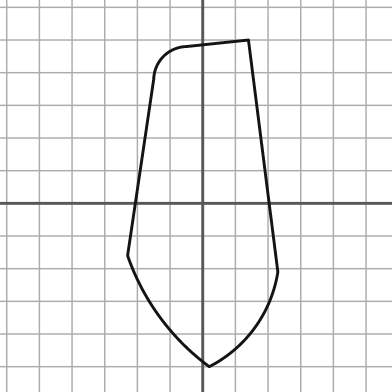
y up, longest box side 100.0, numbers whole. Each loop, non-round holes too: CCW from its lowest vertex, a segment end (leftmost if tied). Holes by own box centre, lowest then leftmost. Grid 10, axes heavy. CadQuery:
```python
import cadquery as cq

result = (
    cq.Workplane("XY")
    .moveTo(2.0, -50.0)
    .threePointArc((16.0, -38.0), (23.0, -21.0))
    .lineTo(14.0, 50.0)
    .lineTo(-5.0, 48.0)
    .threePointArc((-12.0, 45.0), (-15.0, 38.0))
    .lineTo(-23.0, -16.0)
    .threePointArc((-13.0, -35.0), (2.0, -50.0))
    .close()
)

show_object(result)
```